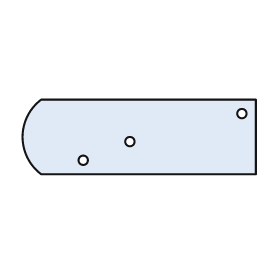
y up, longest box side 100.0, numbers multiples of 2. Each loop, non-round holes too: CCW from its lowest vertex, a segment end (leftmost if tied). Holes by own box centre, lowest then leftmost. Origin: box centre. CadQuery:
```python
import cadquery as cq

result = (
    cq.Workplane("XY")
    .moveTo(-42.0, -16.0)
    .lineTo(50.0, -16.0)
    .lineTo(50.0, 16.0)
    .lineTo(-42.0, 16.0)
    .threePointArc((-50.0, 0.0), (-42.0, -16.0))
    .close()
    .moveTo(-24.0, -10.0)
    .circle(2.0)
    .moveTo(-4.0, -2.0)
    .circle(2.0)
    .moveTo(44.0, 10.0)
    .circle(2.0)
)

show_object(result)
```